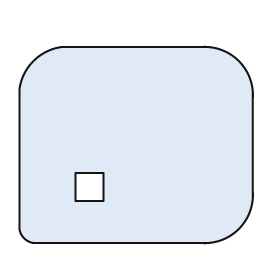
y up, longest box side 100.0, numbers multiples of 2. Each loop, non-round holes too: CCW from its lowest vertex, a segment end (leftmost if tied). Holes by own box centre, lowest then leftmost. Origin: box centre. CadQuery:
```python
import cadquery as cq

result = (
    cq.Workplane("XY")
    .moveTo(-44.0, -42.0)
    .lineTo(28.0, -42.0)
    .threePointArc((44.0, -36.0), (50.0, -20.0))
    .lineTo(50.0, 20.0)
    .threePointArc((44.0, 36.0), (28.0, 42.0))
    .lineTo(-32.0, 42.0)
    .threePointArc((-44.0, 36.0), (-50.0, 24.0))
    .lineTo(-50.0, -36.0)
    .threePointArc((-48.0, -40.0), (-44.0, -42.0))
    .close()
    .moveTo(-26.0, -24.0)
    .lineTo(-14.0, -24.0)
    .lineTo(-14.0, -12.0)
    .lineTo(-26.0, -12.0)
    .close()
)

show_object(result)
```